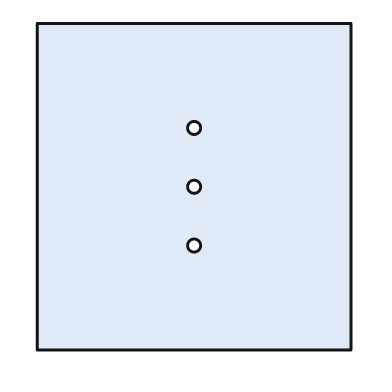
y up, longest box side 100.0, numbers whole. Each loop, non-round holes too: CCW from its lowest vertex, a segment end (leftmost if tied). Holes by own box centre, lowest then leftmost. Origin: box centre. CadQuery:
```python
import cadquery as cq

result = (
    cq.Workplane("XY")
    .moveTo(-48.0, -50.0)
    .lineTo(48.0, -50.0)
    .lineTo(48.0, 50.0)
    .lineTo(-48.0, 50.0)
    .close()
    .moveTo(0.0, -18.0)
    .circle(2.0)
    .moveTo(0.0, 0.0)
    .circle(2.0)
    .moveTo(0.0, 18.0)
    .circle(2.0)
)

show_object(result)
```